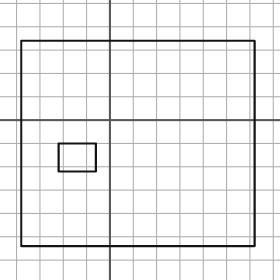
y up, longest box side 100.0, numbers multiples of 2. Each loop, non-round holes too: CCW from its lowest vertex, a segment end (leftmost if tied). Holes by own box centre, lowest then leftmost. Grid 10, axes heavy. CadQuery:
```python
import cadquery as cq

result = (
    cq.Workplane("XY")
    .moveTo(-38.0, -54.0)
    .lineTo(62.0, -54.0)
    .lineTo(62.0, 34.0)
    .lineTo(-38.0, 34.0)
    .close()
    .moveTo(-22.0, -22.0)
    .lineTo(-6.0, -22.0)
    .lineTo(-6.0, -10.0)
    .lineTo(-22.0, -10.0)
    .close()
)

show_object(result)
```